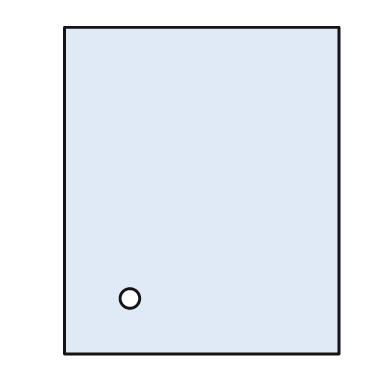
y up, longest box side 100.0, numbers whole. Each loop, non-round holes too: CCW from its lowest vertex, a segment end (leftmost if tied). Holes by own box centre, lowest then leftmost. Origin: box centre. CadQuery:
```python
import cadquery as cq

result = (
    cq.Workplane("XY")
    .moveTo(-42.0, -50.0)
    .lineTo(42.0, -50.0)
    .lineTo(42.0, 50.0)
    .lineTo(-42.0, 50.0)
    .close()
    .moveTo(-22.0, -33.0)
    .circle(3.0)
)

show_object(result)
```